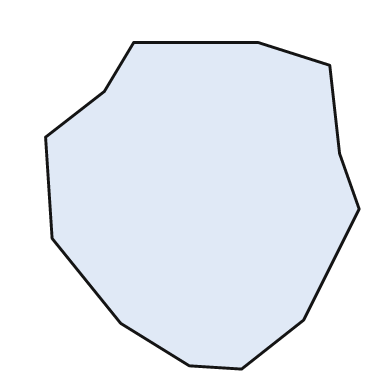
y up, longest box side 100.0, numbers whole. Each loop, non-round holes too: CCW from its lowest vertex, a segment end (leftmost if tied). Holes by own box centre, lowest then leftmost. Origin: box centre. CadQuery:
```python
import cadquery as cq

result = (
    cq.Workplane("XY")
    .moveTo(12.0, -50.0)
    .lineTo(31.0, -35.0)
    .lineTo(48.0, -1.0)
    .lineTo(42.0, 16.0)
    .lineTo(39.0, 43.0)
    .lineTo(17.0, 50.0)
    .lineTo(-21.0, 50.0)
    .lineTo(-30.0, 35.0)
    .lineTo(-48.0, 21.0)
    .lineTo(-46.0, -10.0)
    .lineTo(-25.0, -36.0)
    .lineTo(-4.0, -49.0)
    .close()
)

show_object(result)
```